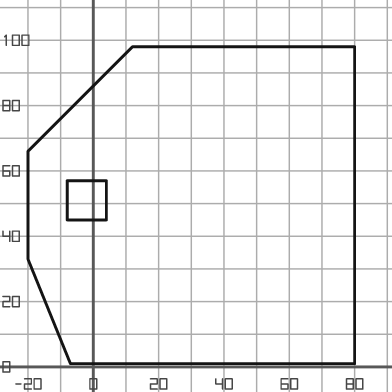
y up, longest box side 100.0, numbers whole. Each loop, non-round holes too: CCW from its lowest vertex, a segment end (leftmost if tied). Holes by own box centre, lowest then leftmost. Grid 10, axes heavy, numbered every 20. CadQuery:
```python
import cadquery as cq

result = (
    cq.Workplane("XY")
    .moveTo(-7.0, 1.0)
    .lineTo(80.0, 1.0)
    .lineTo(80.0, 98.0)
    .lineTo(12.0, 98.0)
    .lineTo(-20.0, 66.0)
    .lineTo(-20.0, 33.0)
    .close()
    .moveTo(-8.0, 45.0)
    .lineTo(4.0, 45.0)
    .lineTo(4.0, 57.0)
    .lineTo(-8.0, 57.0)
    .close()
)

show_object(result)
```